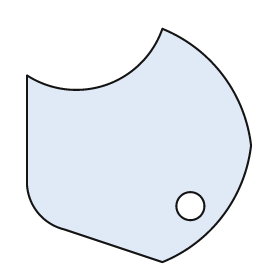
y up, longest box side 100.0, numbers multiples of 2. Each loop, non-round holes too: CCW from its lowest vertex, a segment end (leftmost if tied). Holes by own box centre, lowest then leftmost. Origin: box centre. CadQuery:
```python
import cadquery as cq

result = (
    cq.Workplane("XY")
    .moveTo(10.0, -50.0)
    .threePointArc((36.0, -30.0), (48.0, 0.0))
    .threePointArc((36.0, 30.0), (10.0, 50.0))
    .threePointArc((-14.0, 26.0), (-48.0, 30.0))
    .lineTo(-48.0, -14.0)
    .threePointArc((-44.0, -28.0), (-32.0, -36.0))
    .close()
    .moveTo(22.0, -26.0)
    .circle(6.0)
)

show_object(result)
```